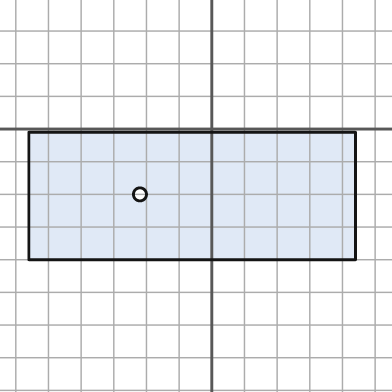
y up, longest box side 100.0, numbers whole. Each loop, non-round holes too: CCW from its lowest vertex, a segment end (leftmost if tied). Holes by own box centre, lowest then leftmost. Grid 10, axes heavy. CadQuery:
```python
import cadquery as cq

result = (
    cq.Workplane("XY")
    .moveTo(-56.0, -40.0)
    .lineTo(44.0, -40.0)
    .lineTo(44.0, -1.0)
    .lineTo(-56.0, -1.0)
    .close()
    .moveTo(-22.0, -20.0)
    .circle(2.0)
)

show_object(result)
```